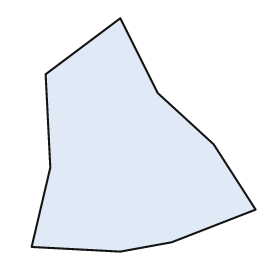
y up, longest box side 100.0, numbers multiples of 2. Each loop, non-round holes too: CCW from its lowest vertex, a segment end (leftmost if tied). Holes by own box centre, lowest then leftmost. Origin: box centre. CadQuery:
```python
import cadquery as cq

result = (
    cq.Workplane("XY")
    .moveTo(-10.0, -50.0)
    .lineTo(12.0, -46.0)
    .lineTo(48.0, -32.0)
    .lineTo(30.0, -4.0)
    .lineTo(6.0, 18.0)
    .lineTo(-10.0, 50.0)
    .lineTo(-42.0, 26.0)
    .lineTo(-40.0, -14.0)
    .lineTo(-48.0, -48.0)
    .close()
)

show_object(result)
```